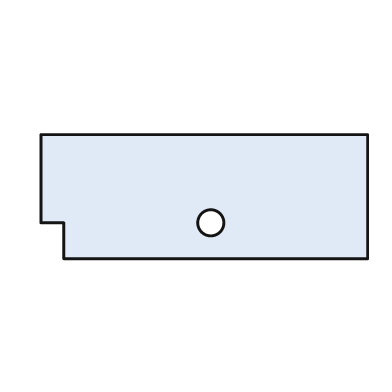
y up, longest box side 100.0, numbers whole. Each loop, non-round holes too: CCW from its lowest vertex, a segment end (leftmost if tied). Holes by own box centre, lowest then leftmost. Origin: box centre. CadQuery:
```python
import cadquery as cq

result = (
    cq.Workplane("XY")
    .moveTo(-43.0, -19.0)
    .lineTo(50.0, -19.0)
    .lineTo(50.0, 19.0)
    .lineTo(-50.0, 19.0)
    .lineTo(-50.0, -8.0)
    .lineTo(-43.0, -8.0)
    .close()
    .moveTo(2.0, -8.0)
    .circle(4.0)
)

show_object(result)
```